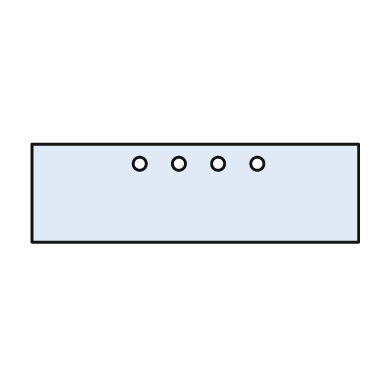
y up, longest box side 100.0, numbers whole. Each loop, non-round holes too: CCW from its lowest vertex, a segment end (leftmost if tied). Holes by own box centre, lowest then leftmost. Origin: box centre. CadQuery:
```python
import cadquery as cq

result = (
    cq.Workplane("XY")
    .moveTo(-50.0, -15.0)
    .lineTo(50.0, -15.0)
    .lineTo(50.0, 15.0)
    .lineTo(-50.0, 15.0)
    .close()
    .moveTo(-17.0, 9.0)
    .circle(2.0)
    .moveTo(-5.0, 9.0)
    .circle(2.0)
    .moveTo(7.0, 9.0)
    .circle(2.0)
    .moveTo(19.0, 9.0)
    .circle(2.0)
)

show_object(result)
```